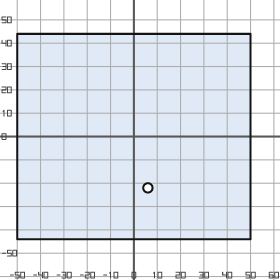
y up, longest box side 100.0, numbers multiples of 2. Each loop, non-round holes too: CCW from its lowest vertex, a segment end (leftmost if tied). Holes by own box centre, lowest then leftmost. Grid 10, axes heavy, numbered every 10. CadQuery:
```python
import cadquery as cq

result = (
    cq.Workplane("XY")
    .moveTo(-50.0, -44.0)
    .lineTo(50.0, -44.0)
    .lineTo(50.0, 44.0)
    .lineTo(-50.0, 44.0)
    .close()
    .moveTo(6.0, -22.0)
    .circle(2.0)
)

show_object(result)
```